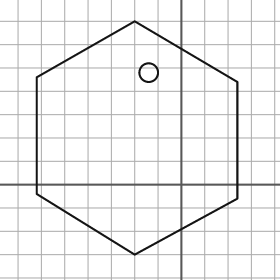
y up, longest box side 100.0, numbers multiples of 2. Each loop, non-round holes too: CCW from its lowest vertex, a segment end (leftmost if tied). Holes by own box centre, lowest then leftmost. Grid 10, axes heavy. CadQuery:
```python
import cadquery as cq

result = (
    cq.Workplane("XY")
    .moveTo(-20.0, -30.0)
    .lineTo(24.0, -6.0)
    .lineTo(24.0, 44.0)
    .lineTo(-20.0, 70.0)
    .lineTo(-62.0, 46.0)
    .lineTo(-62.0, -4.0)
    .close()
    .moveTo(-14.0, 48.0)
    .circle(4.0)
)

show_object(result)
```